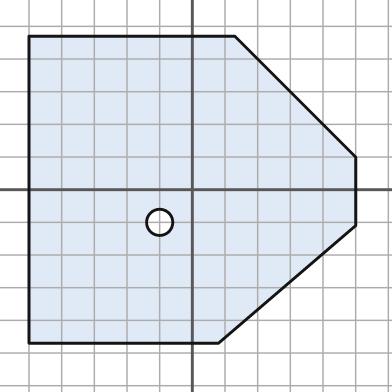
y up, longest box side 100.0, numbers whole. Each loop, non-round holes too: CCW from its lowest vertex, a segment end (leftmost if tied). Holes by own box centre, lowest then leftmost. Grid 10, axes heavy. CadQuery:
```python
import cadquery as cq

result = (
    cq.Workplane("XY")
    .moveTo(-50.0, -47.0)
    .lineTo(8.0, -47.0)
    .lineTo(50.0, -11.0)
    .lineTo(50.0, 10.0)
    .lineTo(13.0, 47.0)
    .lineTo(-50.0, 47.0)
    .close()
    .moveTo(-10.0, -10.0)
    .circle(4.0)
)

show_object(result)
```